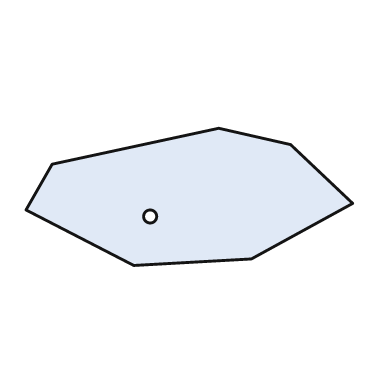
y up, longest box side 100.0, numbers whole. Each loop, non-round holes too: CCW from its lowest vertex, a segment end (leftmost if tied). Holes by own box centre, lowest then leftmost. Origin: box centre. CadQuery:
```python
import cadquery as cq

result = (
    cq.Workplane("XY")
    .moveTo(-17.0, -21.0)
    .lineTo(19.0, -19.0)
    .lineTo(50.0, -2.0)
    .lineTo(31.0, 16.0)
    .lineTo(9.0, 21.0)
    .lineTo(-42.0, 10.0)
    .lineTo(-50.0, -4.0)
    .close()
    .moveTo(-12.0, -6.0)
    .circle(2.0)
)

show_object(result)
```